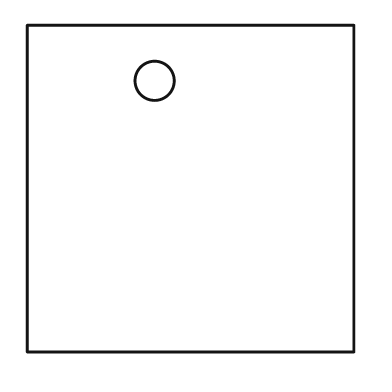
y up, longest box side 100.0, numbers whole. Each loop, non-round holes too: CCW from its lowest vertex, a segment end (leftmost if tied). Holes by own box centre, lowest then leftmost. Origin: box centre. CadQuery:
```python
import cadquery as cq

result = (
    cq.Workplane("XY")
    .moveTo(-50.0, -50.0)
    .lineTo(50.0, -50.0)
    .lineTo(50.0, 50.0)
    .lineTo(-50.0, 50.0)
    .close()
    .moveTo(-11.0, 33.0)
    .circle(6.0)
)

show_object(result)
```